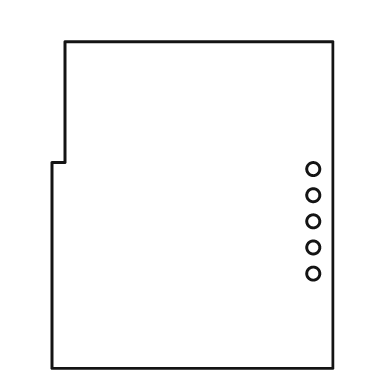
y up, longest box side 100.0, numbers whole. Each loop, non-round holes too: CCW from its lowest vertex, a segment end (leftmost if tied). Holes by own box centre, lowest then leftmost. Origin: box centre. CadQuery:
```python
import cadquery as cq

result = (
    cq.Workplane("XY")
    .moveTo(-43.0, -50.0)
    .lineTo(43.0, -50.0)
    .lineTo(43.0, 50.0)
    .lineTo(-39.0, 50.0)
    .lineTo(-39.0, 13.0)
    .lineTo(-43.0, 13.0)
    .close()
    .moveTo(37.0, -21.0)
    .circle(2.0)
    .moveTo(37.0, -13.0)
    .circle(2.0)
    .moveTo(37.0, -5.0)
    .circle(2.0)
    .moveTo(37.0, 3.0)
    .circle(2.0)
    .moveTo(37.0, 11.0)
    .circle(2.0)
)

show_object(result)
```